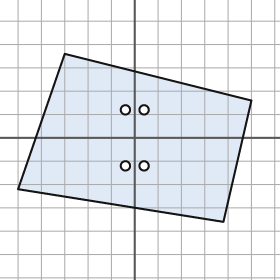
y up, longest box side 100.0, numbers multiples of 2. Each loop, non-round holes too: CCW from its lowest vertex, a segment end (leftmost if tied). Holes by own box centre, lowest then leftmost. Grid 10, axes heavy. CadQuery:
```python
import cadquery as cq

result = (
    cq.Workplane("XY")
    .moveTo(38.0, -36.0)
    .lineTo(50.0, 16.0)
    .lineTo(-30.0, 36.0)
    .lineTo(-50.0, -22.0)
    .close()
    .moveTo(-4.0, -12.0)
    .circle(2.0)
    .moveTo(4.0, -12.0)
    .circle(2.0)
    .moveTo(-4.0, 12.0)
    .circle(2.0)
    .moveTo(4.0, 12.0)
    .circle(2.0)
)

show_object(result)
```